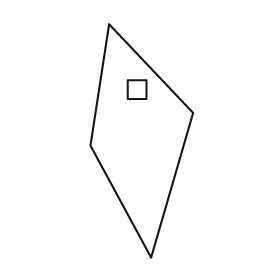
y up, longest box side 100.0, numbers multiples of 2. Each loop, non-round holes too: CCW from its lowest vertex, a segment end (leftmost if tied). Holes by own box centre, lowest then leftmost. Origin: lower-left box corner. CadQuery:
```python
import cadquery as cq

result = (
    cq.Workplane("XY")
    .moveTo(26.0, 0.0)
    .lineTo(44.0, 62.0)
    .lineTo(8.0, 100.0)
    .lineTo(0.0, 48.0)
    .close()
    .moveTo(16.0, 68.0)
    .lineTo(24.0, 68.0)
    .lineTo(24.0, 76.0)
    .lineTo(16.0, 76.0)
    .close()
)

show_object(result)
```